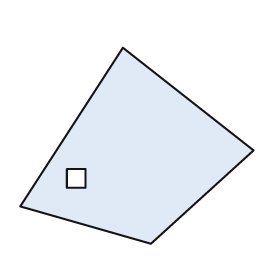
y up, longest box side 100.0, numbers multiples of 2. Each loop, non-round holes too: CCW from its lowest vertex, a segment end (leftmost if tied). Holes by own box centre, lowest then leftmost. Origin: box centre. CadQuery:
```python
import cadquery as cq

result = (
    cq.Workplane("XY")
    .moveTo(6.0, -42.0)
    .lineTo(50.0, -2.0)
    .lineTo(-6.0, 42.0)
    .lineTo(-50.0, -26.0)
    .close()
    .moveTo(-30.0, -18.0)
    .lineTo(-22.0, -18.0)
    .lineTo(-22.0, -10.0)
    .lineTo(-30.0, -10.0)
    .close()
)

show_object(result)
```